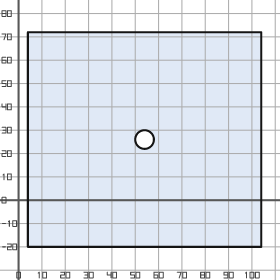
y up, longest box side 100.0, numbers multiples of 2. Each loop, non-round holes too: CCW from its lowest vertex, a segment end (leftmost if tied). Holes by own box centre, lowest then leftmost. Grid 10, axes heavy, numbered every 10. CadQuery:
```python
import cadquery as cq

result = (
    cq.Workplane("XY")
    .moveTo(4.0, -20.0)
    .lineTo(104.0, -20.0)
    .lineTo(104.0, 72.0)
    .lineTo(4.0, 72.0)
    .close()
    .moveTo(54.0, 26.0)
    .circle(4.0)
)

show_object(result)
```